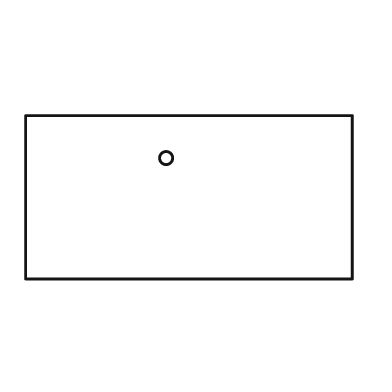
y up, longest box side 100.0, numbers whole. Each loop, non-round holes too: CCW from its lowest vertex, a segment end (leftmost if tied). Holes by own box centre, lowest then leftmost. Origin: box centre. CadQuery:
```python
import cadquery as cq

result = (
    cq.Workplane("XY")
    .moveTo(-50.0, -25.0)
    .lineTo(50.0, -25.0)
    .lineTo(50.0, 25.0)
    .lineTo(-50.0, 25.0)
    .close()
    .moveTo(-7.0, 12.0)
    .circle(2.0)
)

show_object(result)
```